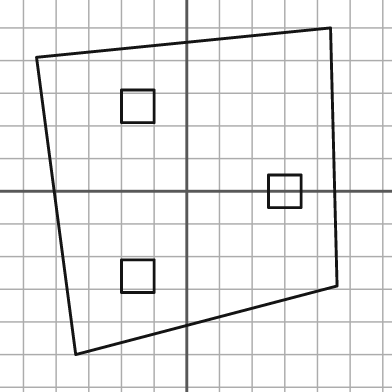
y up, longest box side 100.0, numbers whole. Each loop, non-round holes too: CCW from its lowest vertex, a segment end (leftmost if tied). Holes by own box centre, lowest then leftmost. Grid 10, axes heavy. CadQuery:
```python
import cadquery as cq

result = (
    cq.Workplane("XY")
    .moveTo(-34.0, -50.0)
    .lineTo(46.0, -29.0)
    .lineTo(44.0, 50.0)
    .lineTo(-46.0, 41.0)
    .close()
    .moveTo(-20.0, -31.0)
    .lineTo(-10.0, -31.0)
    .lineTo(-10.0, -21.0)
    .lineTo(-20.0, -21.0)
    .close()
    .moveTo(25.0, -5.0)
    .lineTo(35.0, -5.0)
    .lineTo(35.0, 5.0)
    .lineTo(25.0, 5.0)
    .close()
    .moveTo(-20.0, 21.0)
    .lineTo(-10.0, 21.0)
    .lineTo(-10.0, 31.0)
    .lineTo(-20.0, 31.0)
    .close()
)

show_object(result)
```